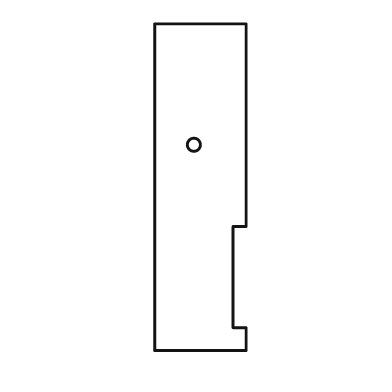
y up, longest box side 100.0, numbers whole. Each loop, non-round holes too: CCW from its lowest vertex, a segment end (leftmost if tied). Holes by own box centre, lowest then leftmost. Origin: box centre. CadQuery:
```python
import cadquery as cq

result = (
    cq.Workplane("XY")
    .moveTo(-14.0, -50.0)
    .lineTo(14.0, -50.0)
    .lineTo(14.0, -43.0)
    .lineTo(10.0, -43.0)
    .lineTo(10.0, -12.0)
    .lineTo(14.0, -12.0)
    .lineTo(14.0, 50.0)
    .lineTo(-14.0, 50.0)
    .close()
    .moveTo(-2.0, 13.0)
    .circle(2.0)
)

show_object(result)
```